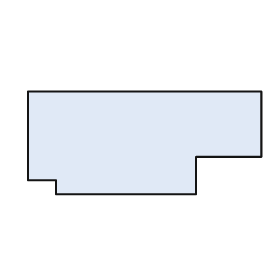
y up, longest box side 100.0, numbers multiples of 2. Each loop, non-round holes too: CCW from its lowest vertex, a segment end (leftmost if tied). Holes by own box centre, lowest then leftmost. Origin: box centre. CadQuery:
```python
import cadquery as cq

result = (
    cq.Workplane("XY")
    .moveTo(-38.0, -22.0)
    .lineTo(22.0, -22.0)
    .lineTo(22.0, -6.0)
    .lineTo(50.0, -6.0)
    .lineTo(50.0, 22.0)
    .lineTo(-50.0, 22.0)
    .lineTo(-50.0, -16.0)
    .lineTo(-38.0, -16.0)
    .close()
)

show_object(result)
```